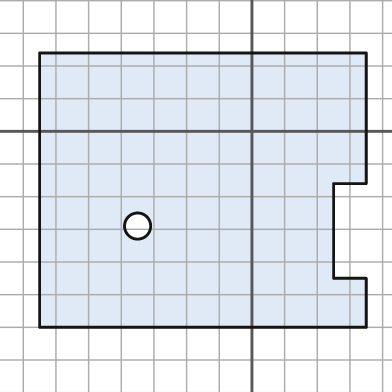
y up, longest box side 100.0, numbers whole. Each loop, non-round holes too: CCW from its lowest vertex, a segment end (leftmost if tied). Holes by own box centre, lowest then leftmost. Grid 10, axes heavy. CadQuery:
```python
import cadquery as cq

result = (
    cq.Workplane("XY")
    .moveTo(-65.0, -60.0)
    .lineTo(35.0, -60.0)
    .lineTo(35.0, -45.0)
    .lineTo(25.0, -45.0)
    .lineTo(25.0, -16.0)
    .lineTo(35.0, -16.0)
    .lineTo(35.0, 24.0)
    .lineTo(-65.0, 24.0)
    .close()
    .moveTo(-35.0, -29.0)
    .circle(4.0)
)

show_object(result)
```